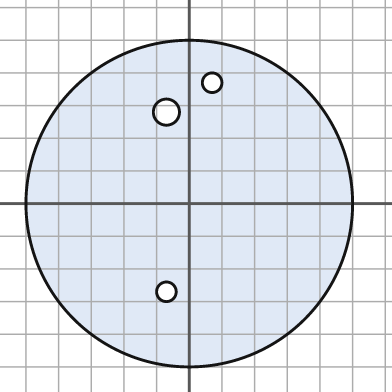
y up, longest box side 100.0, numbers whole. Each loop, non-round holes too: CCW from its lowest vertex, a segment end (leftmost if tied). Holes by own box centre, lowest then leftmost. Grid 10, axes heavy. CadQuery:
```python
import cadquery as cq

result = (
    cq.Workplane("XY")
    .moveTo(0.0, 0.0)
    .circle(50.0)
    .moveTo(-7.0, -27.0)
    .circle(3.0)
    .moveTo(-7.0, 28.0)
    .circle(4.0)
    .moveTo(7.0, 37.0)
    .circle(3.0)
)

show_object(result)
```